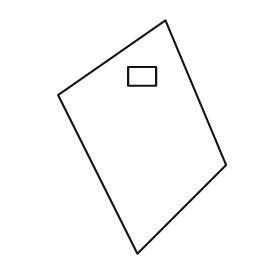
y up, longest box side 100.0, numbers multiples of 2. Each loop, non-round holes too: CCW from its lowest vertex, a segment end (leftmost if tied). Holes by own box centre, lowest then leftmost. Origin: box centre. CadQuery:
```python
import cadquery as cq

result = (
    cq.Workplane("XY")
    .moveTo(-2.0, -50.0)
    .lineTo(36.0, -12.0)
    .lineTo(10.0, 50.0)
    .lineTo(-36.0, 18.0)
    .close()
    .moveTo(-6.0, 22.0)
    .lineTo(6.0, 22.0)
    .lineTo(6.0, 30.0)
    .lineTo(-6.0, 30.0)
    .close()
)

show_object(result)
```